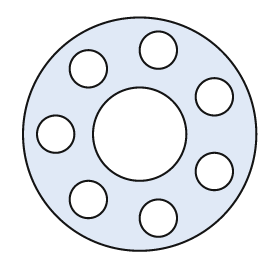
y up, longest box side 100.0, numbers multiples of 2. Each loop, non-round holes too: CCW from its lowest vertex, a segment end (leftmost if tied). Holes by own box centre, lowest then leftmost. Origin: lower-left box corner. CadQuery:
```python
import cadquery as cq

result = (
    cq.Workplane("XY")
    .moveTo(50.0, 50.0)
    .circle(50.0)
    .moveTo(58.0, 14.0)
    .circle(8.0)
    .moveTo(28.0, 22.0)
    .circle(8.0)
    .moveTo(82.0, 34.0)
    .circle(8.0)
    .moveTo(14.0, 50.0)
    .circle(8.0)
    .moveTo(50.0, 50.0)
    .circle(20.0)
    .moveTo(82.0, 66.0)
    .circle(8.0)
    .moveTo(28.0, 78.0)
    .circle(8.0)
    .moveTo(58.0, 86.0)
    .circle(8.0)
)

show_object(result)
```